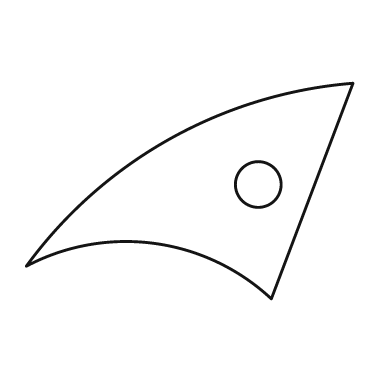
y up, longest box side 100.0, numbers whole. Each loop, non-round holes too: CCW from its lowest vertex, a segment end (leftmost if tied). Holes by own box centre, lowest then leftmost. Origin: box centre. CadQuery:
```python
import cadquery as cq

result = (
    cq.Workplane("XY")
    .moveTo(25.0, -33.0)
    .lineTo(50.0, 33.0)
    .threePointArc((-6.0, 16.0), (-50.0, -23.0))
    .threePointArc((-11.0, -16.0), (25.0, -33.0))
    .close()
    .moveTo(21.0, 2.0)
    .circle(7.0)
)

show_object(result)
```